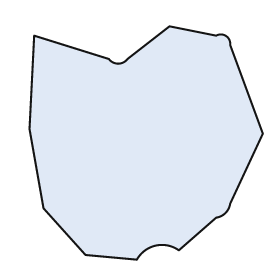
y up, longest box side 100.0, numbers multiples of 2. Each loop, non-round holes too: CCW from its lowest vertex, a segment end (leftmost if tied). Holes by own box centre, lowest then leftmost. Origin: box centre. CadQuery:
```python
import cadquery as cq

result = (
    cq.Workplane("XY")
    .moveTo(-4.0, -50.0)
    .threePointArc((4.0, -44.0), (14.0, -46.0))
    .lineTo(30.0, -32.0)
    .threePointArc((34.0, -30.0), (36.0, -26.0))
    .lineTo(50.0, 4.0)
    .lineTo(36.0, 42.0)
    .threePointArc((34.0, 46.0), (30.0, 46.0))
    .lineTo(10.0, 50.0)
    .lineTo(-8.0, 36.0)
    .threePointArc((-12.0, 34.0), (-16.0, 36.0))
    .lineTo(-48.0, 46.0)
    .lineTo(-50.0, 6.0)
    .lineTo(-44.0, -28.0)
    .lineTo(-26.0, -48.0)
    .close()
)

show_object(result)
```